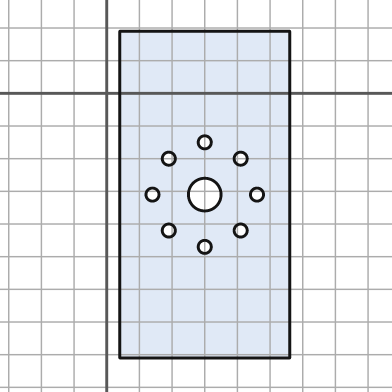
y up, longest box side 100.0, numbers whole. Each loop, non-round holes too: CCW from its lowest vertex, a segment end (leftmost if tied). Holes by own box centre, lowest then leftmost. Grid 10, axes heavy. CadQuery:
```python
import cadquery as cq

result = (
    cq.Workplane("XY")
    .moveTo(4.0, -81.0)
    .lineTo(56.0, -81.0)
    .lineTo(56.0, 19.0)
    .lineTo(4.0, 19.0)
    .close()
    .moveTo(30.0, -47.0)
    .circle(2.0)
    .moveTo(19.0, -42.0)
    .circle(2.0)
    .moveTo(41.0, -42.0)
    .circle(2.0)
    .moveTo(14.0, -31.0)
    .circle(2.0)
    .moveTo(30.0, -31.0)
    .circle(5.0)
    .moveTo(46.0, -31.0)
    .circle(2.0)
    .moveTo(19.0, -20.0)
    .circle(2.0)
    .moveTo(41.0, -20.0)
    .circle(2.0)
    .moveTo(30.0, -15.0)
    .circle(2.0)
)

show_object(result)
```